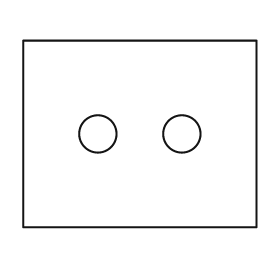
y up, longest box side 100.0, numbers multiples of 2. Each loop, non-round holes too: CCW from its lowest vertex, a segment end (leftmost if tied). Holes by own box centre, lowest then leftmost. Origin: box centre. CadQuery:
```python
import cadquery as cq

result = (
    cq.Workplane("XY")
    .moveTo(-50.0, -40.0)
    .lineTo(50.0, -40.0)
    .lineTo(50.0, 40.0)
    .lineTo(-50.0, 40.0)
    .close()
    .moveTo(-18.0, 0.0)
    .circle(8.0)
    .moveTo(18.0, 0.0)
    .circle(8.0)
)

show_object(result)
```